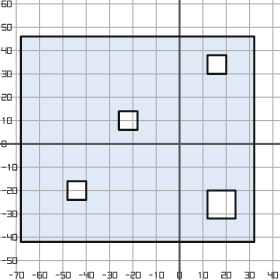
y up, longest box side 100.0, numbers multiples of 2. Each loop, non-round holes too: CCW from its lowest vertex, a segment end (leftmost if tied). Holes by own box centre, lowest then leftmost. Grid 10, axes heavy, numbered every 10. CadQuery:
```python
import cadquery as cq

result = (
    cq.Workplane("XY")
    .moveTo(-68.0, -42.0)
    .lineTo(32.0, -42.0)
    .lineTo(32.0, 46.0)
    .lineTo(-68.0, 46.0)
    .close()
    .moveTo(12.0, -32.0)
    .lineTo(24.0, -32.0)
    .lineTo(24.0, -20.0)
    .lineTo(12.0, -20.0)
    .close()
    .moveTo(-48.0, -24.0)
    .lineTo(-40.0, -24.0)
    .lineTo(-40.0, -16.0)
    .lineTo(-48.0, -16.0)
    .close()
    .moveTo(-26.0, 6.0)
    .lineTo(-18.0, 6.0)
    .lineTo(-18.0, 14.0)
    .lineTo(-26.0, 14.0)
    .close()
    .moveTo(12.0, 30.0)
    .lineTo(20.0, 30.0)
    .lineTo(20.0, 38.0)
    .lineTo(12.0, 38.0)
    .close()
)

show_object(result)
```